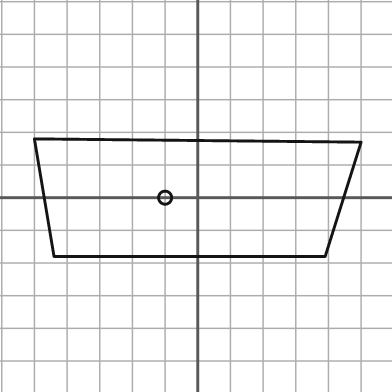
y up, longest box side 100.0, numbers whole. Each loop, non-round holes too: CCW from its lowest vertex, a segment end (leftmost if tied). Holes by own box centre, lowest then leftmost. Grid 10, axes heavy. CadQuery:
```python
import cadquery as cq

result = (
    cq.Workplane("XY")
    .moveTo(-44.0, -18.0)
    .lineTo(39.0, -18.0)
    .lineTo(50.0, 17.0)
    .lineTo(-50.0, 18.0)
    .close()
    .moveTo(-10.0, 0.0)
    .circle(2.0)
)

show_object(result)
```